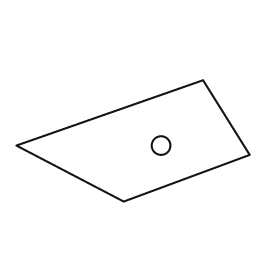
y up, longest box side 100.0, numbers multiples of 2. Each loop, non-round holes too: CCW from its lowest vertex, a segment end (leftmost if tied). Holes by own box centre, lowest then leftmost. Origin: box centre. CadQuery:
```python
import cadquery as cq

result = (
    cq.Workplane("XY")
    .moveTo(-4.0, -26.0)
    .lineTo(50.0, -6.0)
    .lineTo(30.0, 26.0)
    .lineTo(-50.0, -2.0)
    .close()
    .moveTo(12.0, -2.0)
    .circle(4.0)
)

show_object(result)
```